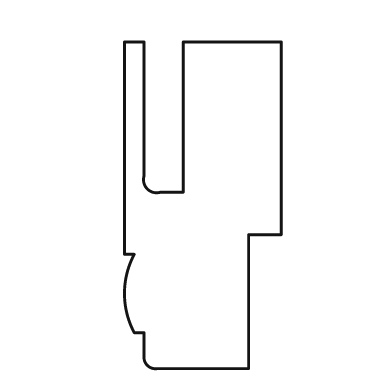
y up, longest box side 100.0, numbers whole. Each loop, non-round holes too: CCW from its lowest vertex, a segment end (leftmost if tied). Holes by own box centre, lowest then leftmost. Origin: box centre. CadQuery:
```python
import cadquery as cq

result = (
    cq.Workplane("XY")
    .moveTo(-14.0, -50.0)
    .lineTo(14.0, -50.0)
    .lineTo(14.0, -9.0)
    .lineTo(24.0, -9.0)
    .lineTo(24.0, 50.0)
    .lineTo(-6.0, 50.0)
    .lineTo(-6.0, 4.0)
    .lineTo(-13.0, 4.0)
    .threePointArc((-17.0, 5.0), (-18.0, 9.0))
    .lineTo(-18.0, 50.0)
    .lineTo(-24.0, 50.0)
    .lineTo(-24.0, -15.0)
    .lineTo(-21.0, -15.0)
    .threePointArc((-24.0, -27.0), (-21.0, -39.0))
    .lineTo(-18.0, -39.0)
    .lineTo(-18.0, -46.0)
    .threePointArc((-17.0, -49.0), (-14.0, -50.0))
    .close()
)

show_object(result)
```